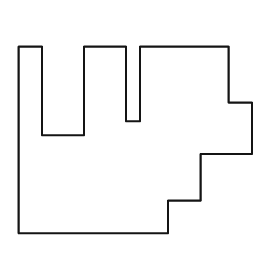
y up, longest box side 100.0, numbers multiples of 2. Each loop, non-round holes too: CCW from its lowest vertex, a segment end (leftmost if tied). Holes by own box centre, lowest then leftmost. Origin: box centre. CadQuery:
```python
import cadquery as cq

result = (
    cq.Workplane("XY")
    .moveTo(-50.0, -40.0)
    .lineTo(14.0, -40.0)
    .lineTo(14.0, -26.0)
    .lineTo(28.0, -26.0)
    .lineTo(28.0, -6.0)
    .lineTo(50.0, -6.0)
    .lineTo(50.0, 16.0)
    .lineTo(40.0, 16.0)
    .lineTo(40.0, 40.0)
    .lineTo(2.0, 40.0)
    .lineTo(2.0, 8.0)
    .lineTo(-4.0, 8.0)
    .lineTo(-4.0, 40.0)
    .lineTo(-22.0, 40.0)
    .lineTo(-22.0, 2.0)
    .lineTo(-40.0, 2.0)
    .lineTo(-40.0, 40.0)
    .lineTo(-50.0, 40.0)
    .close()
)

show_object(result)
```